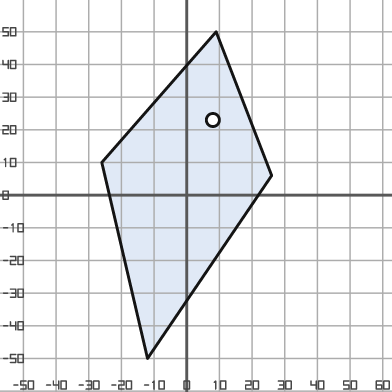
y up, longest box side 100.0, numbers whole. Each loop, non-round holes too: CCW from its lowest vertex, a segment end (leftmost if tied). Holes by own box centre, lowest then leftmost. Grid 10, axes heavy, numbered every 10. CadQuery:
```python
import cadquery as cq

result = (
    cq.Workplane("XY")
    .moveTo(-12.0, -50.0)
    .lineTo(26.0, 6.0)
    .lineTo(9.0, 50.0)
    .lineTo(-26.0, 10.0)
    .close()
    .moveTo(8.0, 23.0)
    .circle(2.0)
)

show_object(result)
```